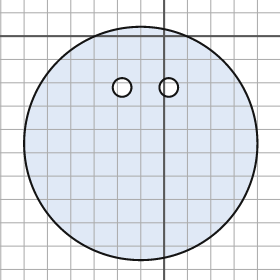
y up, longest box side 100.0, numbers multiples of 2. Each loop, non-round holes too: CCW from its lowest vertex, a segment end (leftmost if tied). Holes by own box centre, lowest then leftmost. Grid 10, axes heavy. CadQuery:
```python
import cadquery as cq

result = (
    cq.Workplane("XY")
    .moveTo(-10.0, -46.0)
    .circle(50.0)
    .moveTo(-18.0, -22.0)
    .circle(4.0)
    .moveTo(2.0, -22.0)
    .circle(4.0)
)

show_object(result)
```